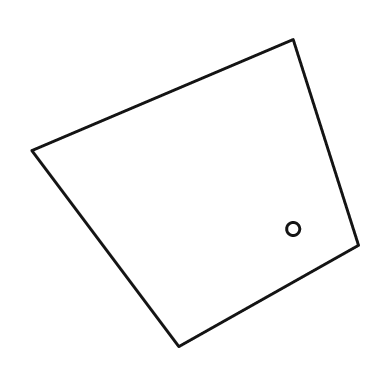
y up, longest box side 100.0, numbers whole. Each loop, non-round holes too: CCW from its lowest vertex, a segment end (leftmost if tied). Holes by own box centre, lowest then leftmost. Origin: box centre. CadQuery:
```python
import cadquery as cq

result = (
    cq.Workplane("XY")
    .moveTo(-5.0, -47.0)
    .lineTo(50.0, -16.0)
    .lineTo(30.0, 47.0)
    .lineTo(-50.0, 13.0)
    .close()
    .moveTo(30.0, -11.0)
    .circle(2.0)
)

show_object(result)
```